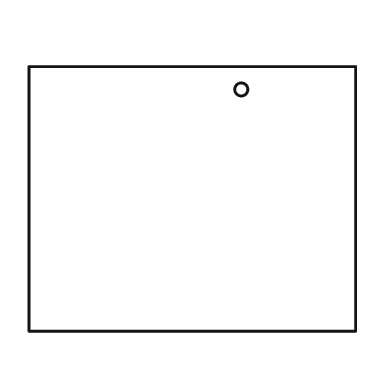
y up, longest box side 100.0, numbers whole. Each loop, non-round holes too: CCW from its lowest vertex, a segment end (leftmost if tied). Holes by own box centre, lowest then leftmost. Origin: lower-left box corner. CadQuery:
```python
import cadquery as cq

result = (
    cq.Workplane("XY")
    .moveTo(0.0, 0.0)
    .lineTo(100.0, 0.0)
    .lineTo(100.0, 81.0)
    .lineTo(0.0, 81.0)
    .close()
    .moveTo(65.0, 74.0)
    .circle(2.0)
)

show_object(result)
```